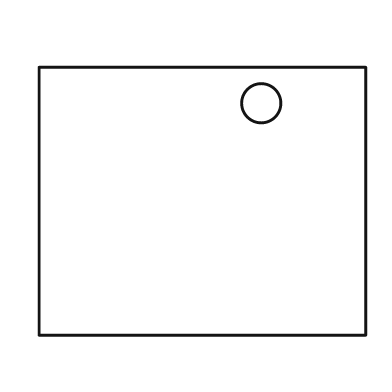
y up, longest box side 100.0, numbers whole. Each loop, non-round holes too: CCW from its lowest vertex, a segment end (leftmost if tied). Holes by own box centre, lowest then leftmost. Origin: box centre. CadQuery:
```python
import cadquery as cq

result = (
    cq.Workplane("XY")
    .moveTo(-50.0, -41.0)
    .lineTo(50.0, -41.0)
    .lineTo(50.0, 41.0)
    .lineTo(-50.0, 41.0)
    .close()
    .moveTo(18.0, 30.0)
    .circle(6.0)
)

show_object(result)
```